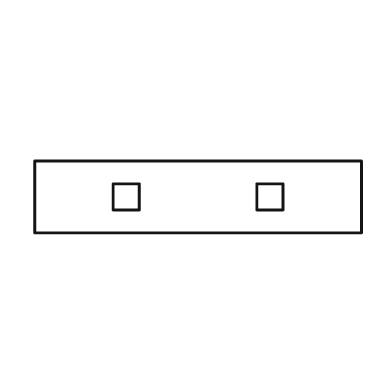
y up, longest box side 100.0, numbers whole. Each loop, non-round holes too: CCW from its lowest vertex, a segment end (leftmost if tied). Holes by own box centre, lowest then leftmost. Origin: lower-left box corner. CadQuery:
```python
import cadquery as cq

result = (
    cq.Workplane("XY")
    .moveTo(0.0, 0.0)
    .lineTo(100.0, 0.0)
    .lineTo(100.0, 22.0)
    .lineTo(0.0, 22.0)
    .close()
    .moveTo(24.0, 7.0)
    .lineTo(32.0, 7.0)
    .lineTo(32.0, 15.0)
    .lineTo(24.0, 15.0)
    .close()
    .moveTo(68.0, 7.0)
    .lineTo(76.0, 7.0)
    .lineTo(76.0, 15.0)
    .lineTo(68.0, 15.0)
    .close()
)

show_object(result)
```